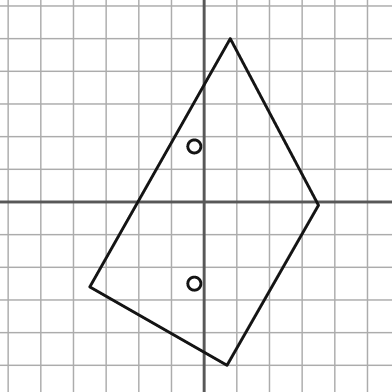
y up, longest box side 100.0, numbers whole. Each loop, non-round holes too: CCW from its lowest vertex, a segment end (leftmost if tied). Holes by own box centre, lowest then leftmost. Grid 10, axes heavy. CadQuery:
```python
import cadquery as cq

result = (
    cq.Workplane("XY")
    .moveTo(7.0, -50.0)
    .lineTo(35.0, -1.0)
    .lineTo(8.0, 50.0)
    .lineTo(-35.0, -26.0)
    .close()
    .moveTo(-3.0, -25.0)
    .circle(2.0)
    .moveTo(-3.0, 17.0)
    .circle(2.0)
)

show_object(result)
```